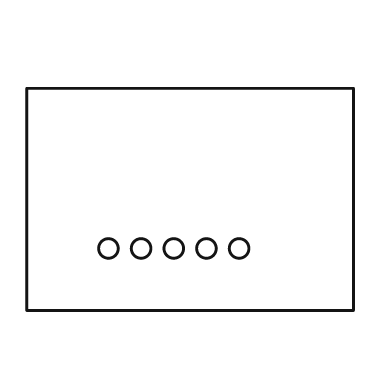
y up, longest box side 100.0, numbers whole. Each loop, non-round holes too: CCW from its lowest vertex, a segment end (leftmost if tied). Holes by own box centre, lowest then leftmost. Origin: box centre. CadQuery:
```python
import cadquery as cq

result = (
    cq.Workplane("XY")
    .moveTo(-50.0, -34.0)
    .lineTo(50.0, -34.0)
    .lineTo(50.0, 34.0)
    .lineTo(-50.0, 34.0)
    .close()
    .moveTo(-25.0, -15.0)
    .circle(3.0)
    .moveTo(-15.0, -15.0)
    .circle(3.0)
    .moveTo(-5.0, -15.0)
    .circle(3.0)
    .moveTo(5.0, -15.0)
    .circle(3.0)
    .moveTo(15.0, -15.0)
    .circle(3.0)
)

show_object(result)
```